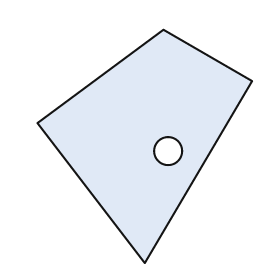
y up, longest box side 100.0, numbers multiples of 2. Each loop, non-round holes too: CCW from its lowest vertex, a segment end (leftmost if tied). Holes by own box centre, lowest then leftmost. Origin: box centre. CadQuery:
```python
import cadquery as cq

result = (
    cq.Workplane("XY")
    .moveTo(0.0, -50.0)
    .lineTo(46.0, 28.0)
    .lineTo(8.0, 50.0)
    .lineTo(-46.0, 10.0)
    .close()
    .moveTo(10.0, -2.0)
    .circle(6.0)
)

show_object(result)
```